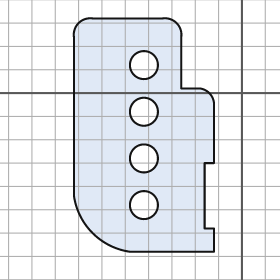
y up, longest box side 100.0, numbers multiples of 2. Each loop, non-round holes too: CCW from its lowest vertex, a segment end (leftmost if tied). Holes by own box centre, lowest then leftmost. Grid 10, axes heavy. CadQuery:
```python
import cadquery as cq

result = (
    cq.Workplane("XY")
    .moveTo(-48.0, -68.0)
    .lineTo(-12.0, -68.0)
    .lineTo(-12.0, -58.0)
    .lineTo(-16.0, -58.0)
    .lineTo(-16.0, -30.0)
    .lineTo(-12.0, -30.0)
    .lineTo(-12.0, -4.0)
    .threePointArc((-14.0, 0.0), (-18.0, 2.0))
    .lineTo(-26.0, 2.0)
    .lineTo(-26.0, 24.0)
    .threePointArc((-28.0, 30.0), (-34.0, 32.0))
    .lineTo(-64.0, 32.0)
    .threePointArc((-70.0, 30.0), (-72.0, 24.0))
    .lineTo(-72.0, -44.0)
    .threePointArc((-64.0, -60.0), (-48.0, -68.0))
    .close()
    .moveTo(-42.0, -48.0)
    .circle(6.0)
    .moveTo(-42.0, -28.0)
    .circle(6.0)
    .moveTo(-42.0, -8.0)
    .circle(6.0)
    .moveTo(-42.0, 12.0)
    .circle(6.0)
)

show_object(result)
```